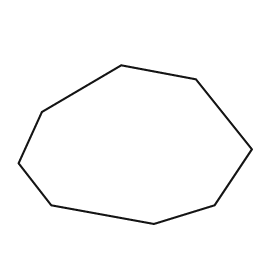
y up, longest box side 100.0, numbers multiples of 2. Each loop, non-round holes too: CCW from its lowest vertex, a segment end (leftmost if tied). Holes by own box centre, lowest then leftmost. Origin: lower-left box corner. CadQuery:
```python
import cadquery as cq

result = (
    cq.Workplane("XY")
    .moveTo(58.0, 0.0)
    .lineTo(84.0, 8.0)
    .lineTo(100.0, 32.0)
    .lineTo(76.0, 62.0)
    .lineTo(44.0, 68.0)
    .lineTo(10.0, 48.0)
    .lineTo(0.0, 26.0)
    .lineTo(14.0, 8.0)
    .close()
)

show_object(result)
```